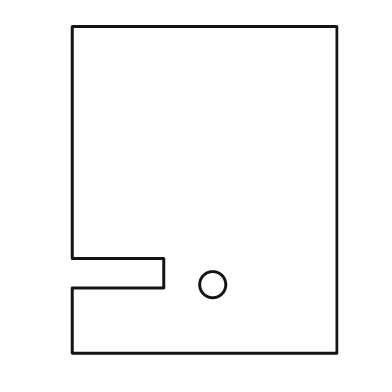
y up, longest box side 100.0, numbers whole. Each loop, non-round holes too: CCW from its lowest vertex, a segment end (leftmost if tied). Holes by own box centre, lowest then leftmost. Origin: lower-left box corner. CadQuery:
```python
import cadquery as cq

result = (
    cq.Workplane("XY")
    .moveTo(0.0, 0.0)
    .lineTo(81.0, 0.0)
    .lineTo(81.0, 100.0)
    .lineTo(0.0, 100.0)
    .lineTo(0.0, 29.0)
    .lineTo(28.0, 29.0)
    .lineTo(28.0, 20.0)
    .lineTo(0.0, 20.0)
    .close()
    .moveTo(43.0, 21.0)
    .circle(4.0)
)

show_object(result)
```